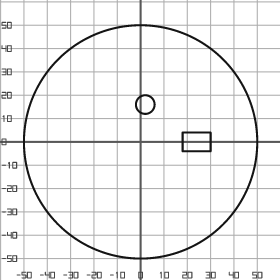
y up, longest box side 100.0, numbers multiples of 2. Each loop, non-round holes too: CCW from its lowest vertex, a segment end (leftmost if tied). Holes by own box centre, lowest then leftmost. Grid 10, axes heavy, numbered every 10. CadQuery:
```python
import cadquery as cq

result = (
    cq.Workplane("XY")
    .moveTo(0.0, 0.0)
    .circle(50.0)
    .moveTo(18.0, -4.0)
    .lineTo(30.0, -4.0)
    .lineTo(30.0, 4.0)
    .lineTo(18.0, 4.0)
    .close()
    .moveTo(2.0, 16.0)
    .circle(4.0)
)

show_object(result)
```